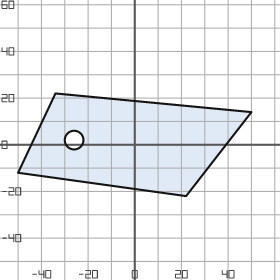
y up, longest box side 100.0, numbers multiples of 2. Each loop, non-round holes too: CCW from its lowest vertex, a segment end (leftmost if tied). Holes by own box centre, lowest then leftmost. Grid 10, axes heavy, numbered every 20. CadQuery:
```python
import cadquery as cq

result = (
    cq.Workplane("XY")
    .moveTo(22.0, -22.0)
    .lineTo(50.0, 14.0)
    .lineTo(-34.0, 22.0)
    .lineTo(-50.0, -12.0)
    .close()
    .moveTo(-26.0, 2.0)
    .circle(4.0)
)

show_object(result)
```